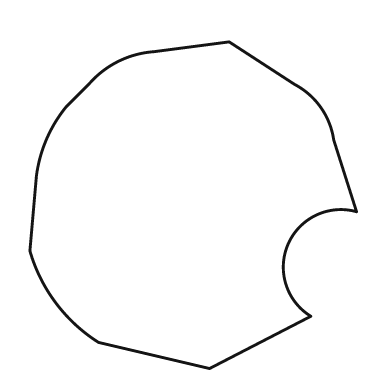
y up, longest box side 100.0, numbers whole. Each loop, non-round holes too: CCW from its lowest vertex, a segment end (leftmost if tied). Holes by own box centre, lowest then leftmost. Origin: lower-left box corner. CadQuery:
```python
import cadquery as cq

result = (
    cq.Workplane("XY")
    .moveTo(55.0, 0.0)
    .lineTo(86.0, 16.0)
    .threePointArc((79.0, 38.0), (100.0, 48.0))
    .lineTo(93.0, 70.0)
    .threePointArc((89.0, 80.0), (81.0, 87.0))
    .lineTo(61.0, 100.0)
    .lineTo(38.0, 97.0)
    .threePointArc((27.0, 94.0), (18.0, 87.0))
    .lineTo(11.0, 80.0)
    .threePointArc((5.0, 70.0), (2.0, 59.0))
    .lineTo(0.0, 36.0)
    .threePointArc((8.0, 20.0), (21.0, 8.0))
    .close()
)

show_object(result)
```